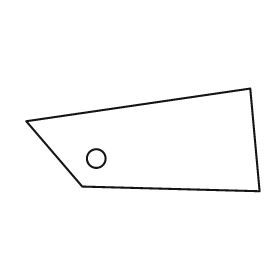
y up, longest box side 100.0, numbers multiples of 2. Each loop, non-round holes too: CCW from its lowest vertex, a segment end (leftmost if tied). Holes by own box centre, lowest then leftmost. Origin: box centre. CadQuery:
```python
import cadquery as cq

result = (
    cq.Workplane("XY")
    .moveTo(50.0, -22.0)
    .lineTo(46.0, 22.0)
    .lineTo(-50.0, 8.0)
    .lineTo(-26.0, -20.0)
    .close()
    .moveTo(-20.0, -8.0)
    .circle(4.0)
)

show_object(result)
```